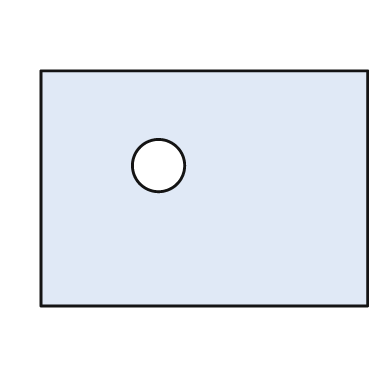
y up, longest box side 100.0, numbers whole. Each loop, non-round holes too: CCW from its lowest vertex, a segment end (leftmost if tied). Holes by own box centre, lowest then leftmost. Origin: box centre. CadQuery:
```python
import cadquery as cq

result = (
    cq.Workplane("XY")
    .moveTo(-50.0, -36.0)
    .lineTo(50.0, -36.0)
    .lineTo(50.0, 36.0)
    .lineTo(-50.0, 36.0)
    .close()
    .moveTo(-14.0, 7.0)
    .circle(8.0)
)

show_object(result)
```